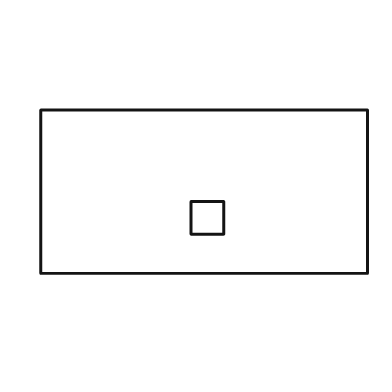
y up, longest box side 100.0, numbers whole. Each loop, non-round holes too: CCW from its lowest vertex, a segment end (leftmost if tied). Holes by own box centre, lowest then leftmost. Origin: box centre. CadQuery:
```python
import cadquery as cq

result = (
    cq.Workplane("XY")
    .moveTo(-50.0, -25.0)
    .lineTo(50.0, -25.0)
    .lineTo(50.0, 25.0)
    .lineTo(-50.0, 25.0)
    .close()
    .moveTo(-4.0, -13.0)
    .lineTo(6.0, -13.0)
    .lineTo(6.0, -3.0)
    .lineTo(-4.0, -3.0)
    .close()
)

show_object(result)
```